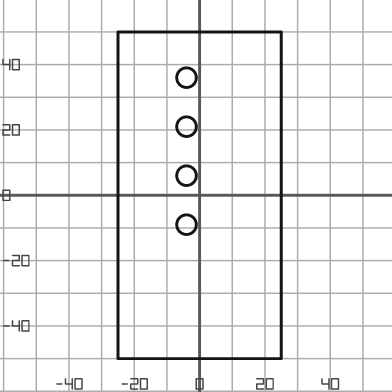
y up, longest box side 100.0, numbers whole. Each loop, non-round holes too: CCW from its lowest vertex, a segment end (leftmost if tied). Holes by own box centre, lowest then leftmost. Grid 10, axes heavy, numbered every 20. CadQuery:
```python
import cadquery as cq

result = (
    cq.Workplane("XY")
    .moveTo(-25.0, -50.0)
    .lineTo(25.0, -50.0)
    .lineTo(25.0, 50.0)
    .lineTo(-25.0, 50.0)
    .close()
    .moveTo(-4.0, -9.0)
    .circle(3.0)
    .moveTo(-4.0, 6.0)
    .circle(3.0)
    .moveTo(-4.0, 21.0)
    .circle(3.0)
    .moveTo(-4.0, 36.0)
    .circle(3.0)
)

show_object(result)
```